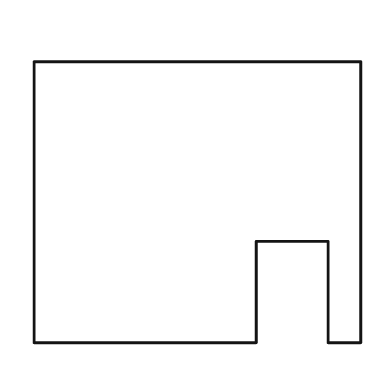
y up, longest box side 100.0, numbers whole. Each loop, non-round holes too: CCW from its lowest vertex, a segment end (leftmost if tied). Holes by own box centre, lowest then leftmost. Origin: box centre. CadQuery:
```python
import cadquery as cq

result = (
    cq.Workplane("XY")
    .moveTo(-50.0, -43.0)
    .lineTo(18.0, -43.0)
    .lineTo(18.0, -12.0)
    .lineTo(40.0, -12.0)
    .lineTo(40.0, -43.0)
    .lineTo(50.0, -43.0)
    .lineTo(50.0, 43.0)
    .lineTo(-50.0, 43.0)
    .close()
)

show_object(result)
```